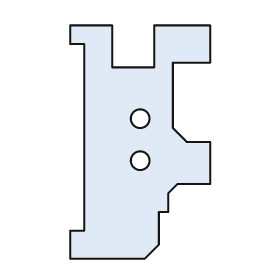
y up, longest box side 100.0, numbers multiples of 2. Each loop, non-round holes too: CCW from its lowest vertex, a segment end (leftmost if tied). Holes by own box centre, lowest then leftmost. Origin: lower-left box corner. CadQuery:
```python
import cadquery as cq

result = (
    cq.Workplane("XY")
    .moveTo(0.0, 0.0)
    .lineTo(32.0, 0.0)
    .lineTo(38.0, 6.0)
    .lineTo(38.0, 20.0)
    .lineTo(42.0, 20.0)
    .lineTo(42.0, 28.0)
    .lineTo(46.0, 32.0)
    .lineTo(60.0, 32.0)
    .lineTo(60.0, 50.0)
    .lineTo(50.0, 50.0)
    .lineTo(44.0, 56.0)
    .lineTo(44.0, 84.0)
    .lineTo(60.0, 84.0)
    .lineTo(60.0, 100.0)
    .lineTo(36.0, 100.0)
    .lineTo(36.0, 82.0)
    .lineTo(18.0, 82.0)
    .lineTo(18.0, 100.0)
    .lineTo(0.0, 100.0)
    .lineTo(0.0, 92.0)
    .lineTo(6.0, 92.0)
    .lineTo(6.0, 12.0)
    .lineTo(0.0, 12.0)
    .close()
    .moveTo(30.0, 42.0)
    .circle(4.0)
    .moveTo(30.0, 60.0)
    .circle(4.0)
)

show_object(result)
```